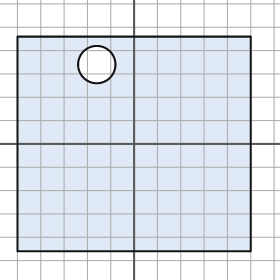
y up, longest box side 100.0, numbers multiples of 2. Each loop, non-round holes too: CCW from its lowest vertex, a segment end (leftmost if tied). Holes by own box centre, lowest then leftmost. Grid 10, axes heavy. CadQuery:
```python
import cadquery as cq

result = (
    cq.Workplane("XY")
    .moveTo(-50.0, -46.0)
    .lineTo(50.0, -46.0)
    .lineTo(50.0, 46.0)
    .lineTo(-50.0, 46.0)
    .close()
    .moveTo(-16.0, 34.0)
    .circle(8.0)
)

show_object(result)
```